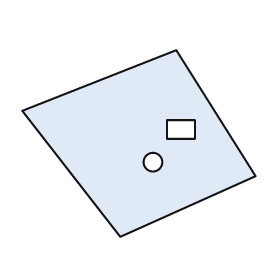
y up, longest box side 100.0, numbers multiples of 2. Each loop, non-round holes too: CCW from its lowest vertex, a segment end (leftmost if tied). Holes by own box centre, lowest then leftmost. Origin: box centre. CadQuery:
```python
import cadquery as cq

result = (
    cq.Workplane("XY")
    .moveTo(-8.0, -40.0)
    .lineTo(50.0, -14.0)
    .lineTo(16.0, 40.0)
    .lineTo(-50.0, 14.0)
    .close()
    .moveTo(6.0, -8.0)
    .circle(4.0)
    .moveTo(12.0, 2.0)
    .lineTo(24.0, 2.0)
    .lineTo(24.0, 10.0)
    .lineTo(12.0, 10.0)
    .close()
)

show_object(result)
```